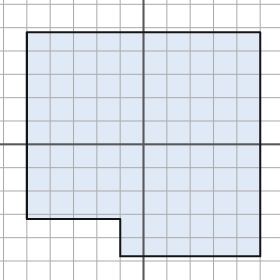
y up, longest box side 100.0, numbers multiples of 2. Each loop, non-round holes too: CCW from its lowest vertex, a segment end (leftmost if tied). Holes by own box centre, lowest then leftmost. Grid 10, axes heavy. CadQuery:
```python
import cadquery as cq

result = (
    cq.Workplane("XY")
    .moveTo(-10.0, -48.0)
    .lineTo(50.0, -48.0)
    .lineTo(50.0, 48.0)
    .lineTo(-50.0, 48.0)
    .lineTo(-50.0, -32.0)
    .lineTo(-10.0, -32.0)
    .close()
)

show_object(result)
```